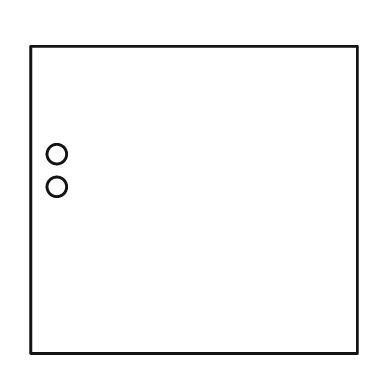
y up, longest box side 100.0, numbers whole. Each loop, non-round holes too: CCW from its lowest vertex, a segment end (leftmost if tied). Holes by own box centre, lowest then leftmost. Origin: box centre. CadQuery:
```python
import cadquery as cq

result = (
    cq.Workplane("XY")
    .moveTo(-50.0, -47.0)
    .lineTo(50.0, -47.0)
    .lineTo(50.0, 47.0)
    .lineTo(-50.0, 47.0)
    .close()
    .moveTo(-42.0, 4.0)
    .circle(3.0)
    .moveTo(-42.0, 14.0)
    .circle(3.0)
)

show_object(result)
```